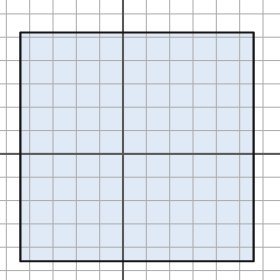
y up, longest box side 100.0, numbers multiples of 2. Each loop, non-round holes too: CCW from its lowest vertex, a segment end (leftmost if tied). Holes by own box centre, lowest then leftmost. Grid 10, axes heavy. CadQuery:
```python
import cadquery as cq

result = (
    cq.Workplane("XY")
    .moveTo(-44.0, -46.0)
    .lineTo(56.0, -46.0)
    .lineTo(56.0, 52.0)
    .lineTo(-44.0, 52.0)
    .close()
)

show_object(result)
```